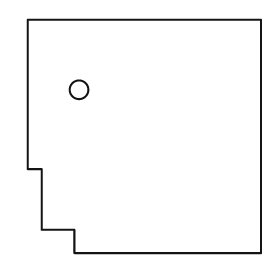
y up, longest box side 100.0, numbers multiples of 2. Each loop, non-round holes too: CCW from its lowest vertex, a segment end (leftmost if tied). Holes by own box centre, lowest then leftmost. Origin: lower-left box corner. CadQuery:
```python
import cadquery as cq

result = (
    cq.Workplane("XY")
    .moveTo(20.0, 0.0)
    .lineTo(100.0, 0.0)
    .lineTo(100.0, 100.0)
    .lineTo(0.0, 100.0)
    .lineTo(0.0, 36.0)
    .lineTo(6.0, 36.0)
    .lineTo(6.0, 10.0)
    .lineTo(20.0, 10.0)
    .close()
    .moveTo(22.0, 70.0)
    .circle(4.0)
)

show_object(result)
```